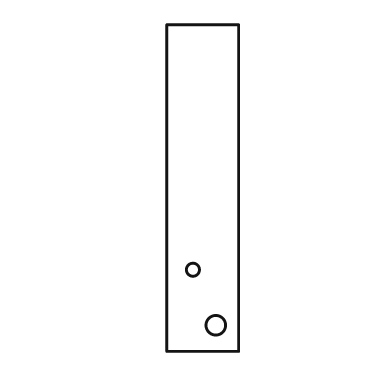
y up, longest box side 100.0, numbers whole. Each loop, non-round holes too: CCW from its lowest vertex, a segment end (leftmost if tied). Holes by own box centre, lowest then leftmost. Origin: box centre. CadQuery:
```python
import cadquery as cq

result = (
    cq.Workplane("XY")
    .moveTo(-11.0, -50.0)
    .lineTo(11.0, -50.0)
    .lineTo(11.0, 50.0)
    .lineTo(-11.0, 50.0)
    .close()
    .moveTo(4.0, -42.0)
    .circle(3.0)
    .moveTo(-3.0, -25.0)
    .circle(2.0)
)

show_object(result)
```